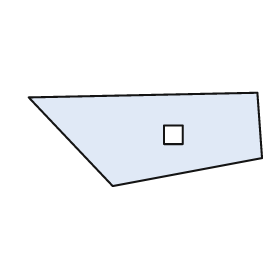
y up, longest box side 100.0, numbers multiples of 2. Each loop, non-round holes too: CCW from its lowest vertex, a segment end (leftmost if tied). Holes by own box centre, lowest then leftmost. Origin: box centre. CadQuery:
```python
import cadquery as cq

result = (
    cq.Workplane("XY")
    .moveTo(-14.0, -20.0)
    .lineTo(50.0, -8.0)
    .lineTo(48.0, 20.0)
    .lineTo(-50.0, 18.0)
    .close()
    .moveTo(8.0, -2.0)
    .lineTo(16.0, -2.0)
    .lineTo(16.0, 6.0)
    .lineTo(8.0, 6.0)
    .close()
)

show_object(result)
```